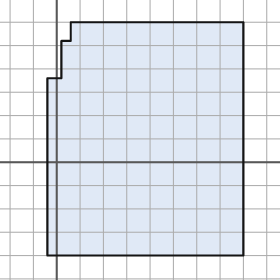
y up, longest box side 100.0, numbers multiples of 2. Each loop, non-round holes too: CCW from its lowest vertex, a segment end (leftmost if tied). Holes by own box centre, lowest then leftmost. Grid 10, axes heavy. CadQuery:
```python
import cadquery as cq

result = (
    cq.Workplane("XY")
    .moveTo(-4.0, -40.0)
    .lineTo(80.0, -40.0)
    .lineTo(80.0, 60.0)
    .lineTo(6.0, 60.0)
    .lineTo(6.0, 52.0)
    .lineTo(2.0, 52.0)
    .lineTo(2.0, 36.0)
    .lineTo(-4.0, 36.0)
    .close()
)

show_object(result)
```